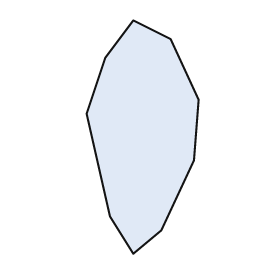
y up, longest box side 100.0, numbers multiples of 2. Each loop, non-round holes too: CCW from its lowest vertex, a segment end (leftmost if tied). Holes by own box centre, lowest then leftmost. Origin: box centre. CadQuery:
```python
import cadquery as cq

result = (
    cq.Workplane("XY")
    .moveTo(-4.0, -50.0)
    .lineTo(8.0, -40.0)
    .lineTo(22.0, -10.0)
    .lineTo(24.0, 16.0)
    .lineTo(12.0, 42.0)
    .lineTo(-4.0, 50.0)
    .lineTo(-16.0, 34.0)
    .lineTo(-24.0, 10.0)
    .lineTo(-14.0, -34.0)
    .close()
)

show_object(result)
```